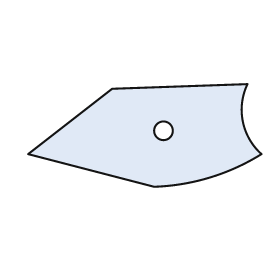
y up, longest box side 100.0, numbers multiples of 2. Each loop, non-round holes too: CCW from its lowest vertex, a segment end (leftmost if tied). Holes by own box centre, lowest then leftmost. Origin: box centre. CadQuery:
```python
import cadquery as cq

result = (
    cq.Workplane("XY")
    .moveTo(4.0, -22.0)
    .threePointArc((28.0, -18.0), (50.0, -8.0))
    .threePointArc((42.0, 6.0), (44.0, 22.0))
    .lineTo(-14.0, 20.0)
    .lineTo(-50.0, -8.0)
    .close()
    .moveTo(8.0, 2.0)
    .circle(4.0)
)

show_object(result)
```